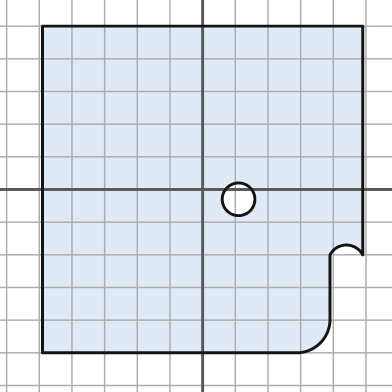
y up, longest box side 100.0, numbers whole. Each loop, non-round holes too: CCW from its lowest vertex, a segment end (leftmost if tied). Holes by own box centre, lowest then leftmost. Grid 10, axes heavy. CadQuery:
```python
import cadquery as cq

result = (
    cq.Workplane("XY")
    .moveTo(-49.0, -50.0)
    .lineTo(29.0, -50.0)
    .threePointArc((36.0, -47.0), (39.0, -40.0))
    .lineTo(39.0, -20.0)
    .threePointArc((44.0, -17.0), (49.0, -20.0))
    .lineTo(49.0, 50.0)
    .lineTo(-49.0, 50.0)
    .close()
    .moveTo(11.0, -3.0)
    .circle(5.0)
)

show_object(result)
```